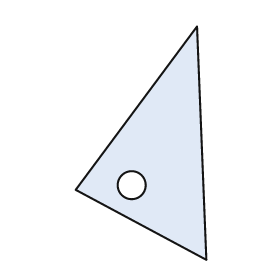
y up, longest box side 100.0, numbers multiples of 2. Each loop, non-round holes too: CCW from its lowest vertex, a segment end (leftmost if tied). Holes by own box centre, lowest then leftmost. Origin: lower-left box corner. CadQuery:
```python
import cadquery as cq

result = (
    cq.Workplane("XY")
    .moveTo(56.0, 0.0)
    .lineTo(52.0, 100.0)
    .lineTo(0.0, 30.0)
    .close()
    .moveTo(24.0, 32.0)
    .circle(6.0)
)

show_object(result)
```